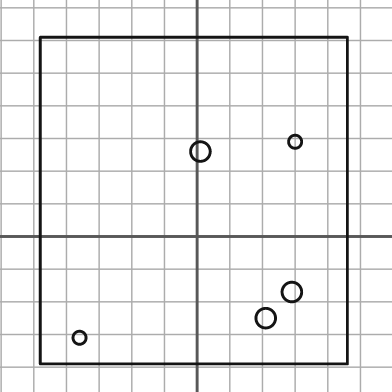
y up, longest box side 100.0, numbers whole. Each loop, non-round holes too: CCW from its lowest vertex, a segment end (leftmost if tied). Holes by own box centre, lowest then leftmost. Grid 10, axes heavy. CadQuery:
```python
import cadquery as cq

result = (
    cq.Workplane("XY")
    .moveTo(-48.0, -39.0)
    .lineTo(46.0, -39.0)
    .lineTo(46.0, 61.0)
    .lineTo(-48.0, 61.0)
    .close()
    .moveTo(-36.0, -31.0)
    .circle(2.0)
    .moveTo(21.0, -25.0)
    .circle(3.0)
    .moveTo(29.0, -17.0)
    .circle(3.0)
    .moveTo(1.0, 26.0)
    .circle(3.0)
    .moveTo(30.0, 29.0)
    .circle(2.0)
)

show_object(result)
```